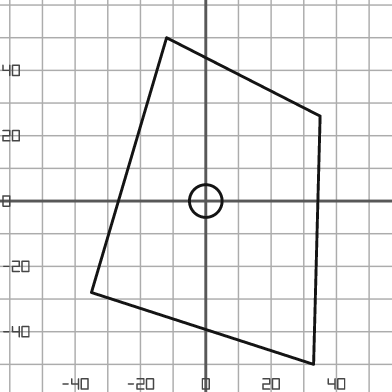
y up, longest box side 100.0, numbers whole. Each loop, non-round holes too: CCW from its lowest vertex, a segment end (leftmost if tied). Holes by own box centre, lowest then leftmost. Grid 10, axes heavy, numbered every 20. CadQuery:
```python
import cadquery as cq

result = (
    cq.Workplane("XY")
    .moveTo(33.0, -50.0)
    .lineTo(35.0, 26.0)
    .lineTo(-12.0, 50.0)
    .lineTo(-35.0, -28.0)
    .close()
    .moveTo(0.0, 0.0)
    .circle(5.0)
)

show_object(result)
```